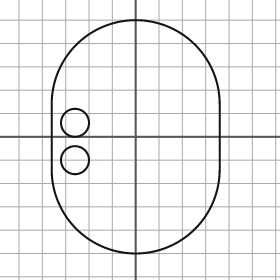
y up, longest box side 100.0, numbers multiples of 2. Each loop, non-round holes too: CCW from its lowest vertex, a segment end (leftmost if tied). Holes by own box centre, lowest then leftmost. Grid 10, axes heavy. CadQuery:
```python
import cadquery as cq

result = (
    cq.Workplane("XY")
    .moveTo(-36.0, -14.0)
    .threePointArc((0.0, -50.0), (36.0, -14.0))
    .lineTo(36.0, 14.0)
    .threePointArc((0.0, 50.0), (-36.0, 14.0))
    .close()
    .moveTo(-26.0, -10.0)
    .circle(6.0)
    .moveTo(-26.0, 6.0)
    .circle(6.0)
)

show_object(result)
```